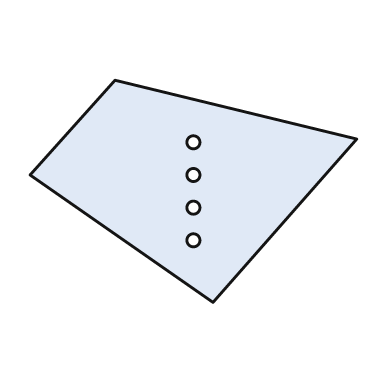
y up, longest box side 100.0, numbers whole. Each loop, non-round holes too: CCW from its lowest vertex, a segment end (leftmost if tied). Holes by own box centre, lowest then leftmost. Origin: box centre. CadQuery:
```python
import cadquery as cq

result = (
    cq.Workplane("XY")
    .moveTo(6.0, -34.0)
    .lineTo(50.0, 16.0)
    .lineTo(-24.0, 34.0)
    .lineTo(-50.0, 5.0)
    .close()
    .moveTo(0.0, -15.0)
    .circle(2.0)
    .moveTo(0.0, -5.0)
    .circle(2.0)
    .moveTo(0.0, 5.0)
    .circle(2.0)
    .moveTo(0.0, 15.0)
    .circle(2.0)
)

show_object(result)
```